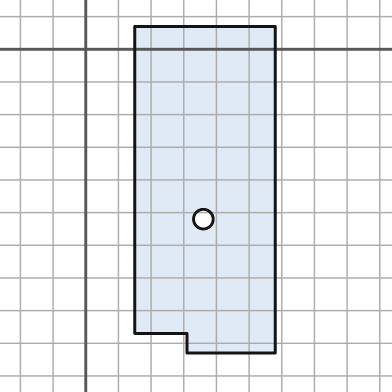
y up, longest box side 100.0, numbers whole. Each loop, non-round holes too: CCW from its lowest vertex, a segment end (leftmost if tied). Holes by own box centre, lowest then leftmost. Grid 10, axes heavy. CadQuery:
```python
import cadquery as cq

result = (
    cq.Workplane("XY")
    .moveTo(31.0, -93.0)
    .lineTo(58.0, -93.0)
    .lineTo(58.0, 7.0)
    .lineTo(15.0, 7.0)
    .lineTo(15.0, -87.0)
    .lineTo(31.0, -87.0)
    .close()
    .moveTo(36.0, -52.0)
    .circle(3.0)
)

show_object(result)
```